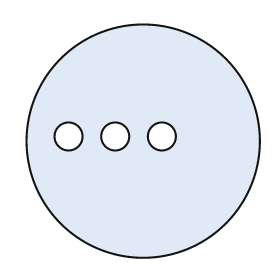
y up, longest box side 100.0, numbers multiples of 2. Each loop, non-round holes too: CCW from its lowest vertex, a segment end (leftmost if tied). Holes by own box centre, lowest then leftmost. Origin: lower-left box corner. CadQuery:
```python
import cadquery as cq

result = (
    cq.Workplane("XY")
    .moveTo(50.0, 50.0)
    .circle(50.0)
    .moveTo(18.0, 52.0)
    .circle(6.0)
    .moveTo(38.0, 52.0)
    .circle(6.0)
    .moveTo(58.0, 52.0)
    .circle(6.0)
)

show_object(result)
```